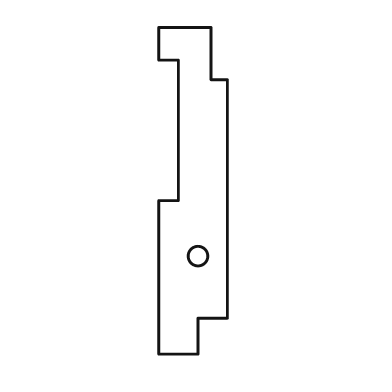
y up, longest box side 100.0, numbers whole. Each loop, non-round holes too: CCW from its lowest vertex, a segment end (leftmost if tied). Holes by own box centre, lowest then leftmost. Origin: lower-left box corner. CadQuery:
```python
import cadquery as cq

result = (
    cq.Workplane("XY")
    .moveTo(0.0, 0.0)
    .lineTo(12.0, 0.0)
    .lineTo(12.0, 11.0)
    .lineTo(21.0, 11.0)
    .lineTo(21.0, 84.0)
    .lineTo(16.0, 84.0)
    .lineTo(16.0, 100.0)
    .lineTo(0.0, 100.0)
    .lineTo(0.0, 90.0)
    .lineTo(6.0, 90.0)
    .lineTo(6.0, 47.0)
    .lineTo(0.0, 47.0)
    .close()
    .moveTo(12.0, 30.0)
    .circle(3.0)
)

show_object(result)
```